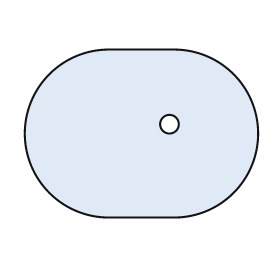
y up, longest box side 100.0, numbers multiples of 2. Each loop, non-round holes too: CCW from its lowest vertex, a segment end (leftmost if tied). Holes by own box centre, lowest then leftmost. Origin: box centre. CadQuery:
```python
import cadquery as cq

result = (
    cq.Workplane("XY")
    .moveTo(-14.0, -36.0)
    .lineTo(14.0, -36.0)
    .threePointArc((50.0, 0.0), (14.0, 36.0))
    .lineTo(-14.0, 36.0)
    .threePointArc((-50.0, 0.0), (-14.0, -36.0))
    .close()
    .moveTo(12.0, 4.0)
    .circle(4.0)
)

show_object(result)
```